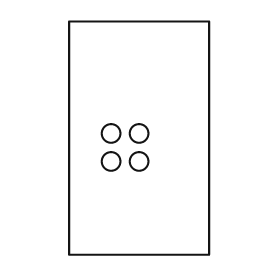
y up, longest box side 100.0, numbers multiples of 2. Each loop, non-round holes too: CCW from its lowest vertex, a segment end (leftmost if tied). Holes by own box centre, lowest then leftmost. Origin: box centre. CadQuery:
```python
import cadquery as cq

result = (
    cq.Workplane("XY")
    .moveTo(-30.0, -50.0)
    .lineTo(30.0, -50.0)
    .lineTo(30.0, 50.0)
    .lineTo(-30.0, 50.0)
    .close()
    .moveTo(-12.0, -10.0)
    .circle(4.0)
    .moveTo(0.0, -10.0)
    .circle(4.0)
    .moveTo(-12.0, 2.0)
    .circle(4.0)
    .moveTo(0.0, 2.0)
    .circle(4.0)
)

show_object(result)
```